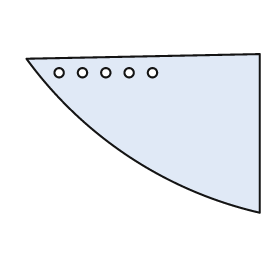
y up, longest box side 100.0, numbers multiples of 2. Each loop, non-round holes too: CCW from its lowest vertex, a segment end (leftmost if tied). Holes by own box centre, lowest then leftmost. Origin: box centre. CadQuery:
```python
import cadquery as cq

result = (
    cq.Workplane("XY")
    .moveTo(50.0, -34.0)
    .lineTo(50.0, 34.0)
    .lineTo(-50.0, 32.0)
    .threePointArc((-6.0, -10.0), (50.0, -34.0))
    .close()
    .moveTo(-36.0, 26.0)
    .circle(2.0)
    .moveTo(-26.0, 26.0)
    .circle(2.0)
    .moveTo(-16.0, 26.0)
    .circle(2.0)
    .moveTo(-6.0, 26.0)
    .circle(2.0)
    .moveTo(4.0, 26.0)
    .circle(2.0)
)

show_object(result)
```